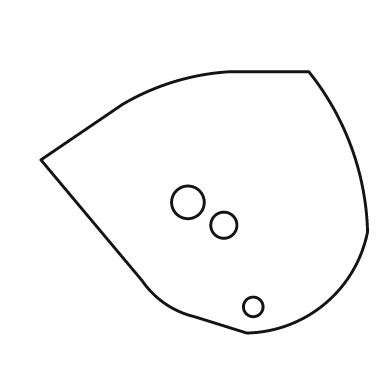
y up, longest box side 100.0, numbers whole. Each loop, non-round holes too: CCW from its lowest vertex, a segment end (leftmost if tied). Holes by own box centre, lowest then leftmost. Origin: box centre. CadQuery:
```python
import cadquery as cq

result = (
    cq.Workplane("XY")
    .moveTo(13.0, -40.0)
    .threePointArc((37.0, -31.0), (50.0, -9.0))
    .threePointArc((45.0, 17.0), (32.0, 40.0))
    .lineTo(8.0, 40.0)
    .threePointArc((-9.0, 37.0), (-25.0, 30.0))
    .lineTo(-50.0, 13.0)
    .lineTo(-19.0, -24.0)
    .threePointArc((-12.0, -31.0), (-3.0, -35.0))
    .close()
    .moveTo(15.0, -32.0)
    .circle(3.0)
    .moveTo(6.0, -7.0)
    .circle(4.0)
    .moveTo(-5.0, 0.0)
    .circle(5.0)
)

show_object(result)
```